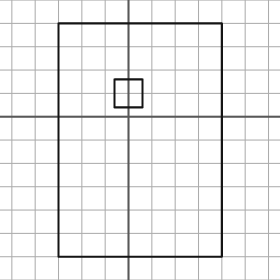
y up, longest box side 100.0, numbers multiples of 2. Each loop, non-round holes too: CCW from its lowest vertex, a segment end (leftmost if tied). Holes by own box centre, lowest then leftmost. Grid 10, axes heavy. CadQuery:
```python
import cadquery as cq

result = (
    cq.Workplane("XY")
    .moveTo(-30.0, -60.0)
    .lineTo(40.0, -60.0)
    .lineTo(40.0, 40.0)
    .lineTo(-30.0, 40.0)
    .close()
    .moveTo(-6.0, 4.0)
    .lineTo(6.0, 4.0)
    .lineTo(6.0, 16.0)
    .lineTo(-6.0, 16.0)
    .close()
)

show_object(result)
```